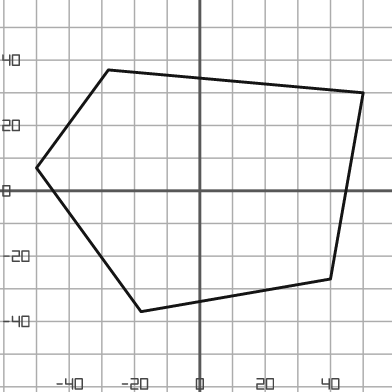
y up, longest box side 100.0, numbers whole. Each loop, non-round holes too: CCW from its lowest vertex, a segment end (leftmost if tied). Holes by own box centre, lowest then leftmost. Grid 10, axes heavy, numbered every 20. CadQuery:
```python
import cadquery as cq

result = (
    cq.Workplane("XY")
    .moveTo(-18.0, -37.0)
    .lineTo(40.0, -27.0)
    .lineTo(50.0, 30.0)
    .lineTo(-28.0, 37.0)
    .lineTo(-50.0, 7.0)
    .close()
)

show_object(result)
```